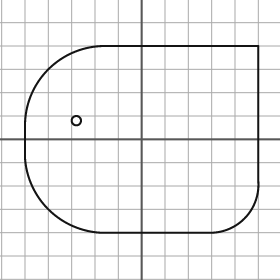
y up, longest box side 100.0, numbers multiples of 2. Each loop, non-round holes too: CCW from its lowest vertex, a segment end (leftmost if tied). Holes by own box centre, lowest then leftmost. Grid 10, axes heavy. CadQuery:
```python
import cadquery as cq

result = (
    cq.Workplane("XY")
    .moveTo(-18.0, -40.0)
    .lineTo(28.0, -40.0)
    .threePointArc((44.0, -34.0), (50.0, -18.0))
    .lineTo(50.0, 40.0)
    .lineTo(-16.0, 40.0)
    .threePointArc((-40.0, 30.0), (-50.0, 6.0))
    .lineTo(-50.0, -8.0)
    .threePointArc((-40.0, -30.0), (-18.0, -40.0))
    .close()
    .moveTo(-28.0, 8.0)
    .circle(2.0)
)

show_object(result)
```